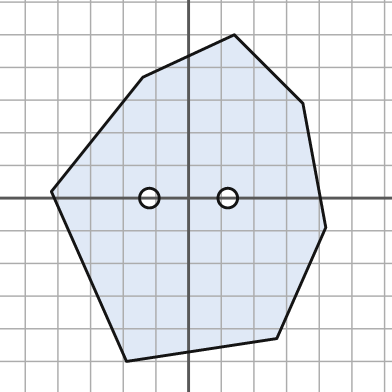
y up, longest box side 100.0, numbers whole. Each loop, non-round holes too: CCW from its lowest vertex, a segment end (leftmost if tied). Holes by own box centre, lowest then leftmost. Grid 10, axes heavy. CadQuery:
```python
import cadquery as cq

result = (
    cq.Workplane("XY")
    .moveTo(-19.0, -50.0)
    .lineTo(27.0, -43.0)
    .lineTo(42.0, -9.0)
    .lineTo(35.0, 29.0)
    .lineTo(14.0, 50.0)
    .lineTo(-14.0, 37.0)
    .lineTo(-42.0, 2.0)
    .close()
    .moveTo(-12.0, 0.0)
    .circle(3.0)
    .moveTo(12.0, 0.0)
    .circle(3.0)
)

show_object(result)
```